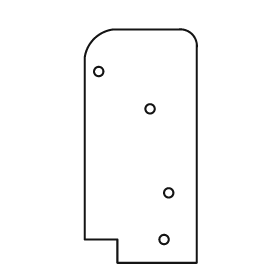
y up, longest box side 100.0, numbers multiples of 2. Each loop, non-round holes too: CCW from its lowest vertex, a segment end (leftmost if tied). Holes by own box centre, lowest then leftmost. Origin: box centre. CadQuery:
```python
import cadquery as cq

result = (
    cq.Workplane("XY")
    .moveTo(-10.0, -50.0)
    .lineTo(24.0, -50.0)
    .lineTo(24.0, 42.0)
    .threePointArc((22.0, 48.0), (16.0, 50.0))
    .lineTo(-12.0, 50.0)
    .threePointArc((-20.0, 46.0), (-24.0, 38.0))
    .lineTo(-24.0, -40.0)
    .lineTo(-10.0, -40.0)
    .close()
    .moveTo(10.0, -40.0)
    .circle(2.0)
    .moveTo(12.0, -20.0)
    .circle(2.0)
    .moveTo(4.0, 16.0)
    .circle(2.0)
    .moveTo(-18.0, 32.0)
    .circle(2.0)
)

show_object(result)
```